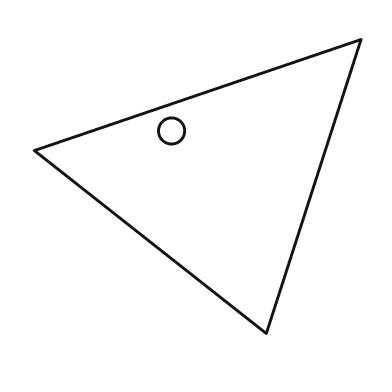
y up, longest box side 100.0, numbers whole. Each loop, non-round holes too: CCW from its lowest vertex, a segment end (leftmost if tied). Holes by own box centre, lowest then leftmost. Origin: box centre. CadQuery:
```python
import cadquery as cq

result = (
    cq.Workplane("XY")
    .moveTo(21.0, -45.0)
    .lineTo(50.0, 45.0)
    .lineTo(-50.0, 11.0)
    .close()
    .moveTo(-8.0, 17.0)
    .circle(4.0)
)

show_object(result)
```